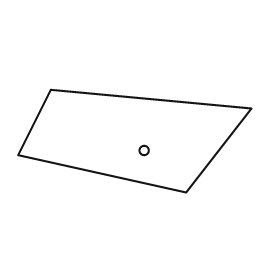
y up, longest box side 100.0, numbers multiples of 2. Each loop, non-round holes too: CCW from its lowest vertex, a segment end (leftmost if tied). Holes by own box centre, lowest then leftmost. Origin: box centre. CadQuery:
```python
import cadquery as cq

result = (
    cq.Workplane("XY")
    .moveTo(22.0, -22.0)
    .lineTo(50.0, 14.0)
    .lineTo(-36.0, 22.0)
    .lineTo(-50.0, -6.0)
    .close()
    .moveTo(4.0, -4.0)
    .circle(2.0)
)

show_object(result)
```